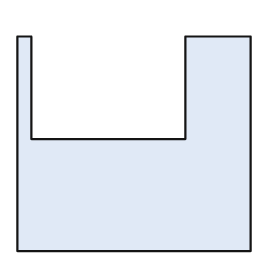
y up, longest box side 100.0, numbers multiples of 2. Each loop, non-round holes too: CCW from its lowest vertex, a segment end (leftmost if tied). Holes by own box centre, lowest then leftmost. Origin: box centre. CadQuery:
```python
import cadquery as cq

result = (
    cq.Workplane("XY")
    .moveTo(-50.0, -46.0)
    .lineTo(50.0, -46.0)
    .lineTo(50.0, 46.0)
    .lineTo(22.0, 46.0)
    .lineTo(22.0, 2.0)
    .lineTo(-44.0, 2.0)
    .lineTo(-44.0, 46.0)
    .lineTo(-50.0, 46.0)
    .close()
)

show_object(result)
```